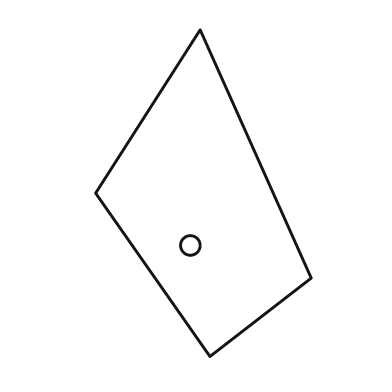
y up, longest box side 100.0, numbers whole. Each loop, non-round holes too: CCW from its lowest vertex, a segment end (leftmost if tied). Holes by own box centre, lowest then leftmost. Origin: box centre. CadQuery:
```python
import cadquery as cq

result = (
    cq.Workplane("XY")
    .moveTo(2.0, -50.0)
    .lineTo(33.0, -26.0)
    .lineTo(-1.0, 50.0)
    .lineTo(-33.0, 0.0)
    .close()
    .moveTo(-4.0, -16.0)
    .circle(3.0)
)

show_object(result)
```